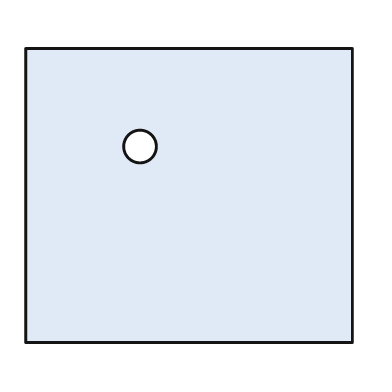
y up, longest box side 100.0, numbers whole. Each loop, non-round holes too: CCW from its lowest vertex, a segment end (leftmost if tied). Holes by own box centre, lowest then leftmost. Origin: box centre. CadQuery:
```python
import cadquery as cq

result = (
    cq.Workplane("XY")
    .moveTo(-50.0, -45.0)
    .lineTo(50.0, -45.0)
    .lineTo(50.0, 45.0)
    .lineTo(-50.0, 45.0)
    .close()
    .moveTo(-15.0, 15.0)
    .circle(5.0)
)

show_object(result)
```